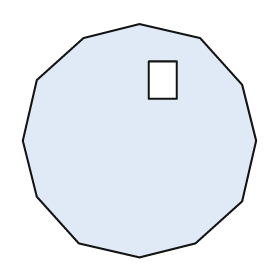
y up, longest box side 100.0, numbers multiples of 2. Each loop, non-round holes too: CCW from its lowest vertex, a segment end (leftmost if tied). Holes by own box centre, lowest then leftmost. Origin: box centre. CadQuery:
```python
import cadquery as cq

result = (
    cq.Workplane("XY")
    .moveTo(0.0, -50.0)
    .lineTo(24.0, -44.0)
    .lineTo(44.0, -26.0)
    .lineTo(50.0, 0.0)
    .lineTo(44.0, 24.0)
    .lineTo(26.0, 44.0)
    .lineTo(0.0, 50.0)
    .lineTo(-24.0, 44.0)
    .lineTo(-44.0, 26.0)
    .lineTo(-50.0, 0.0)
    .lineTo(-44.0, -24.0)
    .lineTo(-26.0, -44.0)
    .close()
    .moveTo(4.0, 18.0)
    .lineTo(16.0, 18.0)
    .lineTo(16.0, 34.0)
    .lineTo(4.0, 34.0)
    .close()
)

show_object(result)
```